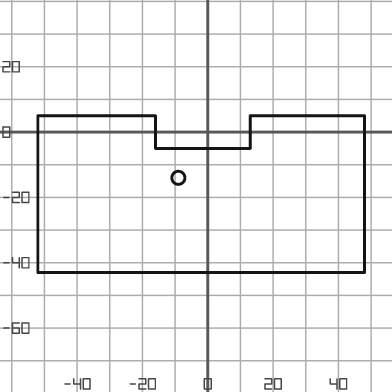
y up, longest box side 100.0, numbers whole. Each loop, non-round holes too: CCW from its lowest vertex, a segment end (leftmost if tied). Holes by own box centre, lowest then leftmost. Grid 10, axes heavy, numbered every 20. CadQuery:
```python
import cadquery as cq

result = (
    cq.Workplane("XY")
    .moveTo(-52.0, -43.0)
    .lineTo(48.0, -43.0)
    .lineTo(48.0, 5.0)
    .lineTo(13.0, 5.0)
    .lineTo(13.0, -5.0)
    .lineTo(-16.0, -5.0)
    .lineTo(-16.0, 5.0)
    .lineTo(-52.0, 5.0)
    .close()
    .moveTo(-9.0, -14.0)
    .circle(2.0)
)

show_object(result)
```